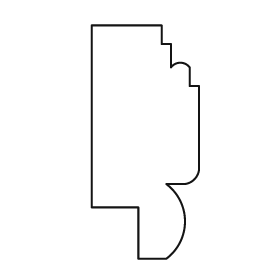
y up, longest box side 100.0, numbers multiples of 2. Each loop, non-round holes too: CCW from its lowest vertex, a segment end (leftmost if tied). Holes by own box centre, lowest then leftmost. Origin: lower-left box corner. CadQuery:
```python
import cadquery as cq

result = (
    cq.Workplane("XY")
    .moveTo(20.0, 0.0)
    .lineTo(32.0, 0.0)
    .threePointArc((40.0, 16.0), (32.0, 32.0))
    .lineTo(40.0, 32.0)
    .threePointArc((44.0, 34.0), (46.0, 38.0))
    .lineTo(46.0, 74.0)
    .lineTo(42.0, 74.0)
    .lineTo(42.0, 82.0)
    .threePointArc((38.0, 84.0), (34.0, 82.0))
    .lineTo(34.0, 92.0)
    .lineTo(30.0, 92.0)
    .lineTo(30.0, 100.0)
    .lineTo(0.0, 100.0)
    .lineTo(0.0, 22.0)
    .lineTo(20.0, 22.0)
    .close()
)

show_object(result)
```